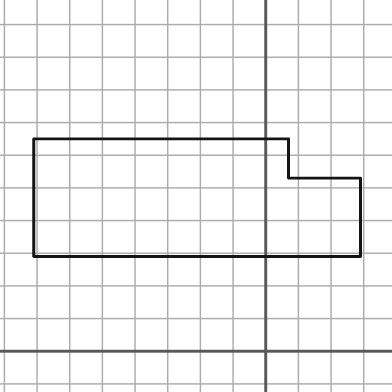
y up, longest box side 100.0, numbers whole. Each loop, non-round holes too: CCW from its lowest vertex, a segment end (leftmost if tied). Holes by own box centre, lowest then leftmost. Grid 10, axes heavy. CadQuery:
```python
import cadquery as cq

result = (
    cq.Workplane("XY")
    .moveTo(-71.0, 29.0)
    .lineTo(29.0, 29.0)
    .lineTo(29.0, 53.0)
    .lineTo(7.0, 53.0)
    .lineTo(7.0, 65.0)
    .lineTo(-71.0, 65.0)
    .close()
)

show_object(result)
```